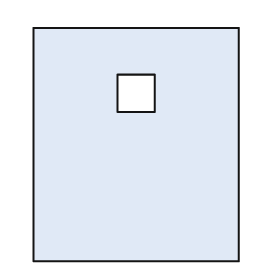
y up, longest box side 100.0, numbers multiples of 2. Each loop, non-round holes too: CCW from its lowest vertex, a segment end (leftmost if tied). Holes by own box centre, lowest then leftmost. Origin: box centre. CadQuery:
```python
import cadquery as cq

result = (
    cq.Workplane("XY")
    .moveTo(-44.0, -50.0)
    .lineTo(44.0, -50.0)
    .lineTo(44.0, 50.0)
    .lineTo(-44.0, 50.0)
    .close()
    .moveTo(-8.0, 14.0)
    .lineTo(8.0, 14.0)
    .lineTo(8.0, 30.0)
    .lineTo(-8.0, 30.0)
    .close()
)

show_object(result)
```